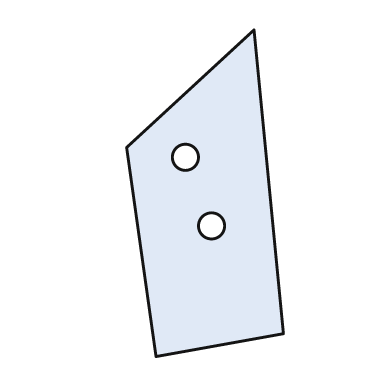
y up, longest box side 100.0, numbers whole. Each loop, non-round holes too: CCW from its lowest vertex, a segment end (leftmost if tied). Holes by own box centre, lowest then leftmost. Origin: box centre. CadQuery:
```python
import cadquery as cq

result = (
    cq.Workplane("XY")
    .moveTo(-15.0, -50.0)
    .lineTo(24.0, -43.0)
    .lineTo(15.0, 50.0)
    .lineTo(-24.0, 14.0)
    .close()
    .moveTo(2.0, -10.0)
    .circle(4.0)
    .moveTo(-6.0, 11.0)
    .circle(4.0)
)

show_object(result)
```